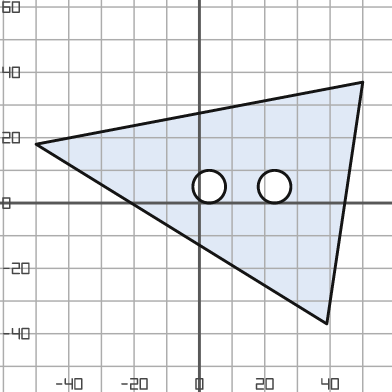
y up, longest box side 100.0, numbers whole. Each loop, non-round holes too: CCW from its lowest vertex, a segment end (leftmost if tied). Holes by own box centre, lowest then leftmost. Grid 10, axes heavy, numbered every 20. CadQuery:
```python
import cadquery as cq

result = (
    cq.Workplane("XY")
    .moveTo(39.0, -37.0)
    .lineTo(50.0, 37.0)
    .lineTo(-50.0, 18.0)
    .close()
    .moveTo(3.0, 5.0)
    .circle(5.0)
    .moveTo(23.0, 5.0)
    .circle(5.0)
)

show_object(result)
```